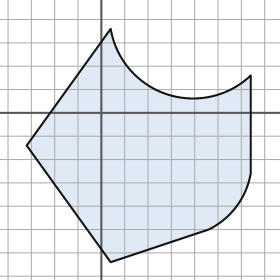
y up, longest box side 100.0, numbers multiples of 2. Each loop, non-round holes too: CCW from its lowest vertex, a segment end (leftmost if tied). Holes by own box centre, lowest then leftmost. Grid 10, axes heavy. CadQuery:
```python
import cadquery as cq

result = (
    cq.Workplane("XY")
    .moveTo(4.0, -64.0)
    .lineTo(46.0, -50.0)
    .threePointArc((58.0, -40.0), (64.0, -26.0))
    .lineTo(64.0, 16.0)
    .threePointArc((28.0, 8.0), (4.0, 36.0))
    .lineTo(-32.0, -14.0)
    .close()
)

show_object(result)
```